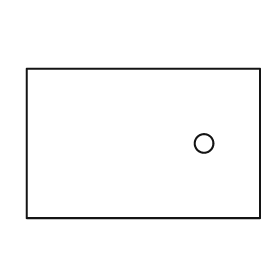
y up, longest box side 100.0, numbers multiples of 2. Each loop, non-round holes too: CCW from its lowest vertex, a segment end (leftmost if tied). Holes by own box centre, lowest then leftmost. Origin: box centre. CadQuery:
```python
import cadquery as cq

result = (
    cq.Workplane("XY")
    .moveTo(-50.0, -32.0)
    .lineTo(50.0, -32.0)
    .lineTo(50.0, 32.0)
    .lineTo(-50.0, 32.0)
    .close()
    .moveTo(26.0, 0.0)
    .circle(4.0)
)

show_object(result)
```